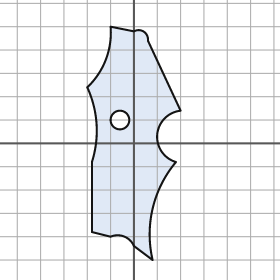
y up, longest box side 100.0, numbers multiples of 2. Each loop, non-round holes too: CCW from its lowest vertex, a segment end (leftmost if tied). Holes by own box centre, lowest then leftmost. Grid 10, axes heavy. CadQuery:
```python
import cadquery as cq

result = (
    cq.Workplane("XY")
    .moveTo(8.0, -50.0)
    .threePointArc((8.0, -28.0), (18.0, -8.0))
    .threePointArc((10.0, 4.0), (20.0, 14.0))
    .lineTo(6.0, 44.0)
    .threePointArc((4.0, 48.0), (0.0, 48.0))
    .lineTo(-10.0, 50.0)
    .threePointArc((-12.0, 36.0), (-20.0, 24.0))
    .threePointArc((-16.0, 8.0), (-18.0, -8.0))
    .lineTo(-18.0, -38.0)
    .lineTo(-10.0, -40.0)
    .threePointArc((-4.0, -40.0), (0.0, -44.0))
    .close()
    .moveTo(-6.0, 10.0)
    .circle(4.0)
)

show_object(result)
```